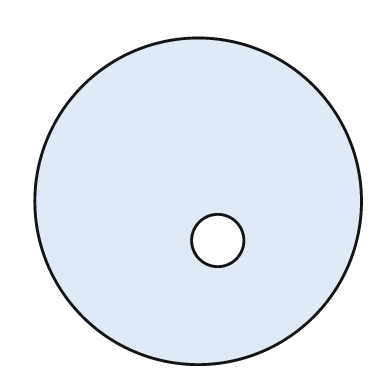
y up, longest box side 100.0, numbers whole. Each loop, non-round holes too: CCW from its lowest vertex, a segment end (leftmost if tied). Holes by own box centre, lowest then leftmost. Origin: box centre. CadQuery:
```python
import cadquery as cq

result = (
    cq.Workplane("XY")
    .moveTo(0.0, 0.0)
    .circle(50.0)
    .moveTo(6.0, -12.0)
    .circle(8.0)
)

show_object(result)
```